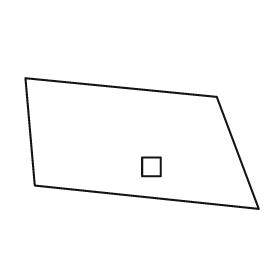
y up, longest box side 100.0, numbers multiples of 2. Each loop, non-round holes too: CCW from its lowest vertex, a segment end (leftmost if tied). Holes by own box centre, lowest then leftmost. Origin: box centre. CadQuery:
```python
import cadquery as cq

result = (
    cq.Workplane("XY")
    .moveTo(50.0, -28.0)
    .lineTo(32.0, 20.0)
    .lineTo(-50.0, 28.0)
    .lineTo(-46.0, -18.0)
    .close()
    .moveTo(0.0, -14.0)
    .lineTo(8.0, -14.0)
    .lineTo(8.0, -6.0)
    .lineTo(0.0, -6.0)
    .close()
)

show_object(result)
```